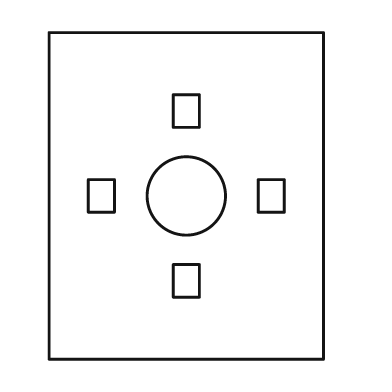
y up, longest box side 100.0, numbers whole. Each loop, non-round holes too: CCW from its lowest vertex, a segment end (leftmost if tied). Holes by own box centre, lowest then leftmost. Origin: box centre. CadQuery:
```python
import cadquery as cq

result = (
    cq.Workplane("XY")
    .moveTo(-42.0, -50.0)
    .lineTo(42.0, -50.0)
    .lineTo(42.0, 50.0)
    .lineTo(-42.0, 50.0)
    .close()
    .moveTo(-4.0, -31.0)
    .lineTo(4.0, -31.0)
    .lineTo(4.0, -21.0)
    .lineTo(-4.0, -21.0)
    .close()
    .moveTo(-30.0, -5.0)
    .lineTo(-22.0, -5.0)
    .lineTo(-22.0, 5.0)
    .lineTo(-30.0, 5.0)
    .close()
    .moveTo(0.0, 0.0)
    .circle(12.0)
    .moveTo(22.0, -5.0)
    .lineTo(30.0, -5.0)
    .lineTo(30.0, 5.0)
    .lineTo(22.0, 5.0)
    .close()
    .moveTo(-4.0, 21.0)
    .lineTo(4.0, 21.0)
    .lineTo(4.0, 31.0)
    .lineTo(-4.0, 31.0)
    .close()
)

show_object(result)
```